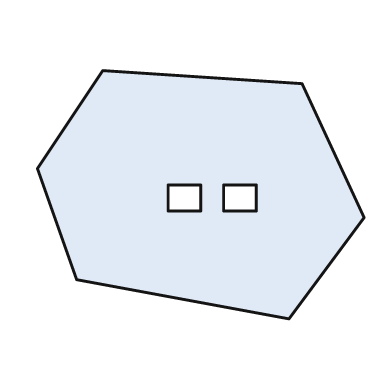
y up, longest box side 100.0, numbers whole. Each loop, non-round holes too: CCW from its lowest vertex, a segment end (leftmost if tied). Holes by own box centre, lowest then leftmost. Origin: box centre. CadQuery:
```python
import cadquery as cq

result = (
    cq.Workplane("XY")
    .moveTo(27.0, -38.0)
    .lineTo(50.0, -7.0)
    .lineTo(31.0, 34.0)
    .lineTo(-30.0, 38.0)
    .lineTo(-50.0, 8.0)
    .lineTo(-38.0, -26.0)
    .close()
    .moveTo(-10.0, -5.0)
    .lineTo(0.0, -5.0)
    .lineTo(0.0, 3.0)
    .lineTo(-10.0, 3.0)
    .close()
    .moveTo(7.0, -5.0)
    .lineTo(17.0, -5.0)
    .lineTo(17.0, 3.0)
    .lineTo(7.0, 3.0)
    .close()
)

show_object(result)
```